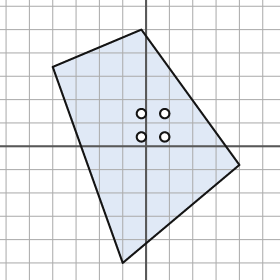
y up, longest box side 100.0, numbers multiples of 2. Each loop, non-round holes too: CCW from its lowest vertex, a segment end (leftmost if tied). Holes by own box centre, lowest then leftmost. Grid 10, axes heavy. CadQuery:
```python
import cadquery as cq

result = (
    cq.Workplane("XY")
    .moveTo(-10.0, -50.0)
    .lineTo(40.0, -8.0)
    .lineTo(-2.0, 50.0)
    .lineTo(-40.0, 34.0)
    .close()
    .moveTo(-2.0, 4.0)
    .circle(2.0)
    .moveTo(8.0, 4.0)
    .circle(2.0)
    .moveTo(-2.0, 14.0)
    .circle(2.0)
    .moveTo(8.0, 14.0)
    .circle(2.0)
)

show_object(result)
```